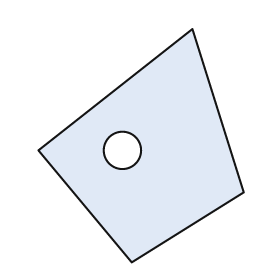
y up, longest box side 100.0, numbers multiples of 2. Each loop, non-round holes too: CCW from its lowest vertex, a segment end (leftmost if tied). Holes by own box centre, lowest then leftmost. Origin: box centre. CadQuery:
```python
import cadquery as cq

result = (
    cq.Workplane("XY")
    .moveTo(-4.0, -50.0)
    .lineTo(44.0, -20.0)
    .lineTo(22.0, 50.0)
    .lineTo(-44.0, -2.0)
    .close()
    .moveTo(-8.0, -2.0)
    .circle(8.0)
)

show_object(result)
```